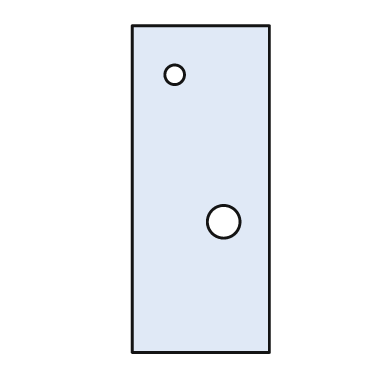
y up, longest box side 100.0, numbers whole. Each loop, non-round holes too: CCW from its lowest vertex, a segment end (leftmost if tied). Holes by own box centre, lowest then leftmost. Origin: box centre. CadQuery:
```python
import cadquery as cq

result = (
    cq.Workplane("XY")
    .moveTo(-21.0, -50.0)
    .lineTo(21.0, -50.0)
    .lineTo(21.0, 50.0)
    .lineTo(-21.0, 50.0)
    .close()
    .moveTo(7.0, -10.0)
    .circle(5.0)
    .moveTo(-8.0, 35.0)
    .circle(3.0)
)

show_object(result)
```